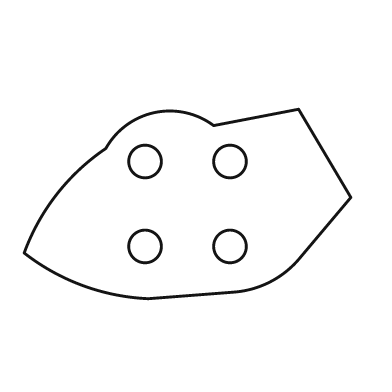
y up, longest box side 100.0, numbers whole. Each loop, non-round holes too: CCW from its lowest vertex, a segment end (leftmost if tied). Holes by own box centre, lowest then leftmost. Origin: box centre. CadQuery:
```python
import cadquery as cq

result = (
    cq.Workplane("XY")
    .moveTo(-12.0, -29.0)
    .lineTo(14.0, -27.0)
    .threePointArc((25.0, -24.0), (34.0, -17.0))
    .lineTo(50.0, 2.0)
    .lineTo(34.0, 29.0)
    .lineTo(8.0, 24.0)
    .threePointArc((-10.0, 28.0), (-25.0, 17.0))
    .threePointArc((-40.0, 3.0), (-50.0, -15.0))
    .threePointArc((-32.0, -25.0), (-12.0, -29.0))
    .close()
    .moveTo(-13.0, -13.0)
    .circle(5.0)
    .moveTo(13.0, -13.0)
    .circle(5.0)
    .moveTo(-13.0, 13.0)
    .circle(5.0)
    .moveTo(13.0, 13.0)
    .circle(5.0)
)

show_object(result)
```